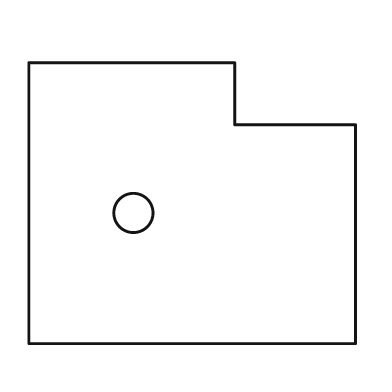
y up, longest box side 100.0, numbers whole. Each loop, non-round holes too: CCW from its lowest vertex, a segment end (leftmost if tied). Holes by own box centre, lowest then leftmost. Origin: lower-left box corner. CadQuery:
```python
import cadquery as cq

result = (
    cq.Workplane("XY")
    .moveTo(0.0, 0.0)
    .lineTo(100.0, 0.0)
    .lineTo(100.0, 67.0)
    .lineTo(63.0, 67.0)
    .lineTo(63.0, 86.0)
    .lineTo(0.0, 86.0)
    .close()
    .moveTo(32.0, 40.0)
    .circle(6.0)
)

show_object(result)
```